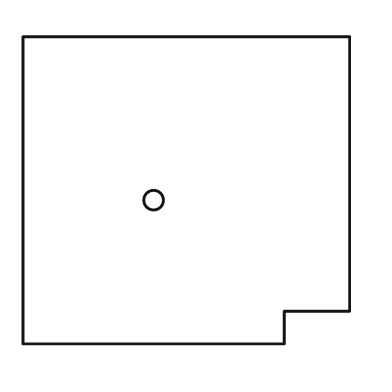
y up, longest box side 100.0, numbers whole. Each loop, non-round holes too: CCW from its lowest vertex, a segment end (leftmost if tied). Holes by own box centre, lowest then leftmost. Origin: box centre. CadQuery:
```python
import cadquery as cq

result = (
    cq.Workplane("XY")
    .moveTo(-50.0, -47.0)
    .lineTo(30.0, -47.0)
    .lineTo(30.0, -37.0)
    .lineTo(50.0, -37.0)
    .lineTo(50.0, 47.0)
    .lineTo(-50.0, 47.0)
    .close()
    .moveTo(-10.0, -3.0)
    .circle(3.0)
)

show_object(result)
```